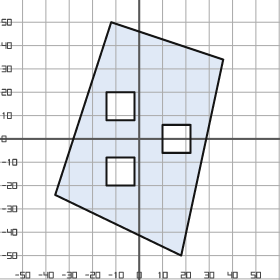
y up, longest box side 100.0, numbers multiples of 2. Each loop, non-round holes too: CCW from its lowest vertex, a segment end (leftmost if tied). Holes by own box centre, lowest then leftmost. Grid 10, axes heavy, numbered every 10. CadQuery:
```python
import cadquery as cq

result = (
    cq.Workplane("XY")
    .moveTo(18.0, -50.0)
    .lineTo(36.0, 34.0)
    .lineTo(-12.0, 50.0)
    .lineTo(-36.0, -24.0)
    .close()
    .moveTo(-14.0, -20.0)
    .lineTo(-2.0, -20.0)
    .lineTo(-2.0, -8.0)
    .lineTo(-14.0, -8.0)
    .close()
    .moveTo(10.0, -6.0)
    .lineTo(22.0, -6.0)
    .lineTo(22.0, 6.0)
    .lineTo(10.0, 6.0)
    .close()
    .moveTo(-14.0, 8.0)
    .lineTo(-2.0, 8.0)
    .lineTo(-2.0, 20.0)
    .lineTo(-14.0, 20.0)
    .close()
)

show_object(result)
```